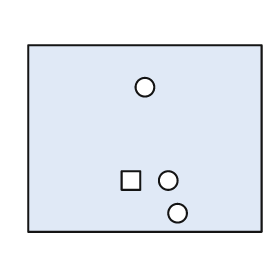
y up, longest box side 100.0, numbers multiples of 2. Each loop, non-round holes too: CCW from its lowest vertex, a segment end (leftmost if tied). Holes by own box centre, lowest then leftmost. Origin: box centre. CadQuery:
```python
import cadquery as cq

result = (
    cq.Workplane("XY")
    .moveTo(-50.0, -40.0)
    .lineTo(50.0, -40.0)
    .lineTo(50.0, 40.0)
    .lineTo(-50.0, 40.0)
    .close()
    .moveTo(14.0, -32.0)
    .circle(4.0)
    .moveTo(-10.0, -22.0)
    .lineTo(-2.0, -22.0)
    .lineTo(-2.0, -14.0)
    .lineTo(-10.0, -14.0)
    .close()
    .moveTo(10.0, -18.0)
    .circle(4.0)
    .moveTo(0.0, 22.0)
    .circle(4.0)
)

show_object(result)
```